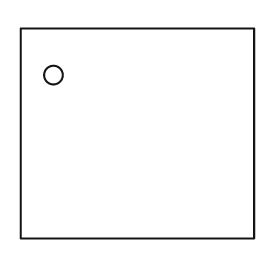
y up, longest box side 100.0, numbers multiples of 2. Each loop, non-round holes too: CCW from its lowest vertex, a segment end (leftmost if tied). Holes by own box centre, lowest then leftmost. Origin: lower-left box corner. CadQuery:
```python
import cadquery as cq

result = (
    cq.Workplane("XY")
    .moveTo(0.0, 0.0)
    .lineTo(100.0, 0.0)
    .lineTo(100.0, 90.0)
    .lineTo(0.0, 90.0)
    .close()
    .moveTo(14.0, 70.0)
    .circle(4.0)
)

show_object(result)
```